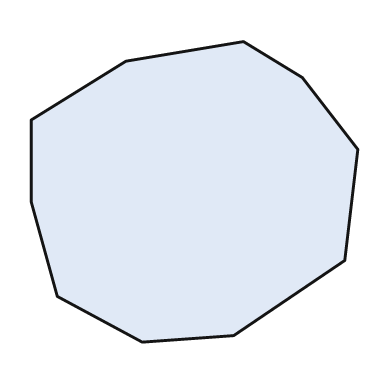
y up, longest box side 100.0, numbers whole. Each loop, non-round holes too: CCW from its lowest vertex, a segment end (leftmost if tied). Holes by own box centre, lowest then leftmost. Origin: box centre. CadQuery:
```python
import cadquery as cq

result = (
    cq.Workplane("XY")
    .moveTo(-16.0, -46.0)
    .lineTo(12.0, -44.0)
    .lineTo(46.0, -21.0)
    .lineTo(50.0, 13.0)
    .lineTo(33.0, 35.0)
    .lineTo(15.0, 46.0)
    .lineTo(-21.0, 40.0)
    .lineTo(-50.0, 22.0)
    .lineTo(-50.0, -3.0)
    .lineTo(-42.0, -32.0)
    .close()
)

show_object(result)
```